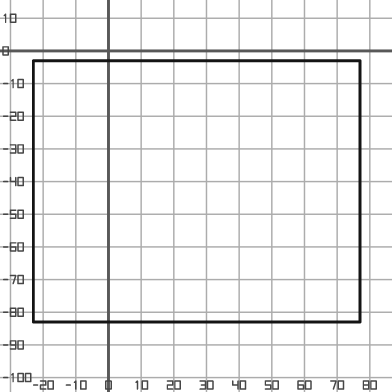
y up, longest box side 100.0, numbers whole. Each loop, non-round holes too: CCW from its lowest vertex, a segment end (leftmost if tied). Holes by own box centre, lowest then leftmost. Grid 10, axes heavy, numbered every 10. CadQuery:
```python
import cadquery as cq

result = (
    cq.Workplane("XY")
    .moveTo(-23.0, -83.0)
    .lineTo(77.0, -83.0)
    .lineTo(77.0, -3.0)
    .lineTo(-23.0, -3.0)
    .close()
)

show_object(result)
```